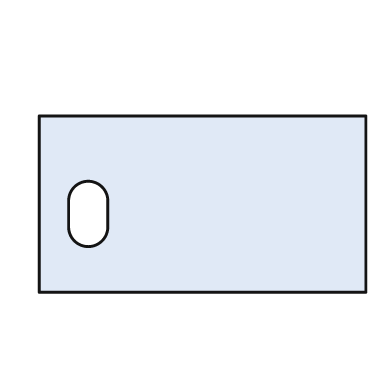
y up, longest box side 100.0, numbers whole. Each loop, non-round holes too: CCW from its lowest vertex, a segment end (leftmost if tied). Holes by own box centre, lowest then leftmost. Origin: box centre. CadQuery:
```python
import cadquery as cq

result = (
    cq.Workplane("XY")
    .moveTo(-50.0, -27.0)
    .lineTo(50.0, -27.0)
    .lineTo(50.0, 27.0)
    .lineTo(-50.0, 27.0)
    .close()
    .moveTo(-41.0, -7.0)
    .threePointArc((-35.0, -13.0), (-29.0, -7.0))
    .lineTo(-29.0, 1.0)
    .threePointArc((-35.0, 7.0), (-41.0, 1.0))
    .close()
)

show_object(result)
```